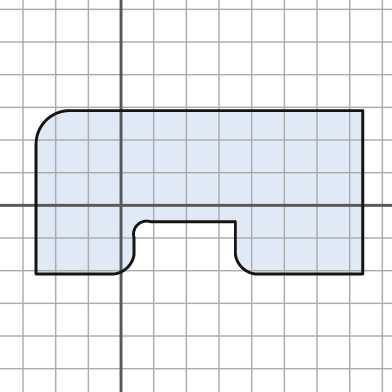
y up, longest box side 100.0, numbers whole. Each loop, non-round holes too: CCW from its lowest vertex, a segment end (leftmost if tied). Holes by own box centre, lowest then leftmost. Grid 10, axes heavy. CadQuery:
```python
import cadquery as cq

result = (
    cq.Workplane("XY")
    .moveTo(-26.0, -21.0)
    .lineTo(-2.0, -21.0)
    .threePointArc((2.0, -19.0), (4.0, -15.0))
    .lineTo(4.0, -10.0)
    .threePointArc((5.0, -6.0), (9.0, -5.0))
    .lineTo(35.0, -5.0)
    .lineTo(35.0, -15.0)
    .threePointArc((37.0, -19.0), (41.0, -21.0))
    .lineTo(74.0, -21.0)
    .lineTo(74.0, 29.0)
    .lineTo(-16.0, 29.0)
    .threePointArc((-23.0, 26.0), (-26.0, 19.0))
    .close()
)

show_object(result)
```